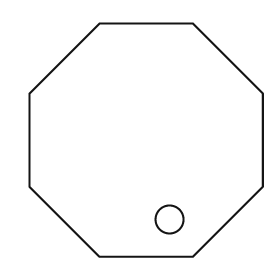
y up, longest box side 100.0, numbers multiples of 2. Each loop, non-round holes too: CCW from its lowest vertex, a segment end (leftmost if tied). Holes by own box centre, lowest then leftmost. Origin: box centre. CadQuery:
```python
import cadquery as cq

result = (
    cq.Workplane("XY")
    .moveTo(-20.0, -50.0)
    .lineTo(20.0, -50.0)
    .lineTo(50.0, -20.0)
    .lineTo(50.0, 20.0)
    .lineTo(20.0, 50.0)
    .lineTo(-20.0, 50.0)
    .lineTo(-50.0, 20.0)
    .lineTo(-50.0, -20.0)
    .close()
    .moveTo(10.0, -34.0)
    .circle(6.0)
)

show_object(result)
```